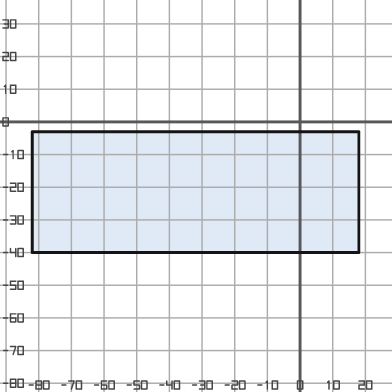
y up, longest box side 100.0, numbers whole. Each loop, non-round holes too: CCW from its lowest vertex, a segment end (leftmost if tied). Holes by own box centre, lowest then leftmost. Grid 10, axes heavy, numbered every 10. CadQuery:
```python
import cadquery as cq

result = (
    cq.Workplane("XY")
    .moveTo(-82.0, -40.0)
    .lineTo(18.0, -40.0)
    .lineTo(18.0, -3.0)
    .lineTo(-82.0, -3.0)
    .close()
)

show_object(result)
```